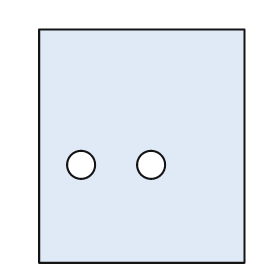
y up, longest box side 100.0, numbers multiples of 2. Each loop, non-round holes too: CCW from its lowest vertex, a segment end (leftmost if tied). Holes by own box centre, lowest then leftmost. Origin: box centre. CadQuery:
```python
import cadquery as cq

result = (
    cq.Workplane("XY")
    .moveTo(-44.0, -50.0)
    .lineTo(44.0, -50.0)
    .lineTo(44.0, 50.0)
    .lineTo(-44.0, 50.0)
    .close()
    .moveTo(-26.0, -8.0)
    .circle(6.0)
    .moveTo(4.0, -8.0)
    .circle(6.0)
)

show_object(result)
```